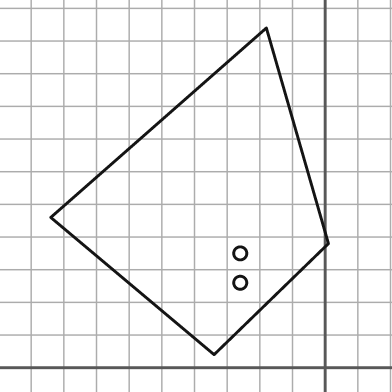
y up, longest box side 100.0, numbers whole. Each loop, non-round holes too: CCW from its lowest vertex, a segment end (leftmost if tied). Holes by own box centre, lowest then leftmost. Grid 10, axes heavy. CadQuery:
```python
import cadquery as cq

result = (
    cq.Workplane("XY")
    .moveTo(-34.0, 4.0)
    .lineTo(1.0, 38.0)
    .lineTo(-18.0, 104.0)
    .lineTo(-84.0, 46.0)
    .close()
    .moveTo(-26.0, 26.0)
    .circle(2.0)
    .moveTo(-26.0, 35.0)
    .circle(2.0)
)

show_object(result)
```